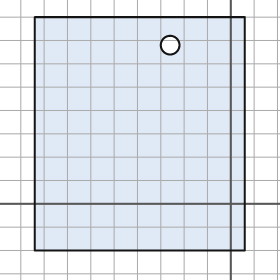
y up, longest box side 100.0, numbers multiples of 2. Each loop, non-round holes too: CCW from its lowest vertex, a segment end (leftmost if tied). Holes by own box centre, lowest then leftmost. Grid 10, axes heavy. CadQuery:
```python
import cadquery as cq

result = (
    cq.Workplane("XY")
    .moveTo(-84.0, -20.0)
    .lineTo(6.0, -20.0)
    .lineTo(6.0, 80.0)
    .lineTo(-84.0, 80.0)
    .close()
    .moveTo(-26.0, 68.0)
    .circle(4.0)
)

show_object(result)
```